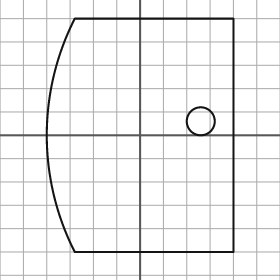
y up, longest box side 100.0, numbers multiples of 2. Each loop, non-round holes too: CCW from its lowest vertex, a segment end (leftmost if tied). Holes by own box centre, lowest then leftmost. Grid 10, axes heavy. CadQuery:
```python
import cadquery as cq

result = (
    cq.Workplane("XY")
    .moveTo(-28.0, -50.0)
    .lineTo(40.0, -50.0)
    .lineTo(40.0, 50.0)
    .lineTo(-28.0, 50.0)
    .threePointArc((-40.0, 0.0), (-28.0, -50.0))
    .close()
    .moveTo(26.0, 6.0)
    .circle(6.0)
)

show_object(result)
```